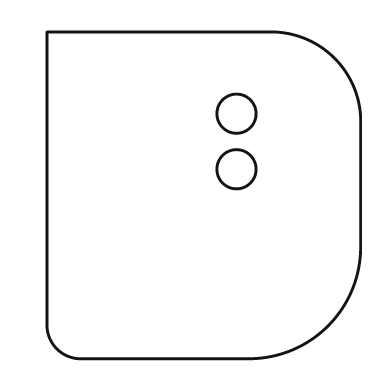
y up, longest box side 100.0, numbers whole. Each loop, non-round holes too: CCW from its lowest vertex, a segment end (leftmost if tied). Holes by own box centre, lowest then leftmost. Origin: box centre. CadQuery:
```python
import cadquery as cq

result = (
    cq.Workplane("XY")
    .moveTo(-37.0, -50.0)
    .lineTo(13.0, -50.0)
    .threePointArc((38.0, -40.0), (48.0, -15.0))
    .lineTo(48.0, 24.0)
    .threePointArc((40.0, 42.0), (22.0, 50.0))
    .lineTo(-48.0, 50.0)
    .lineTo(-48.0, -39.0)
    .threePointArc((-45.0, -47.0), (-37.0, -50.0))
    .close()
    .moveTo(10.0, 8.0)
    .circle(6.0)
    .moveTo(10.0, 25.0)
    .circle(6.0)
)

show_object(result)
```